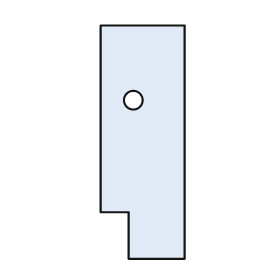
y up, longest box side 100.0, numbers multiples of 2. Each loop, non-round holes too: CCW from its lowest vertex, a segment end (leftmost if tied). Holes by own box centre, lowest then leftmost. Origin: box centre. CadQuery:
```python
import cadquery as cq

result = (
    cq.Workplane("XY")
    .moveTo(-6.0, -50.0)
    .lineTo(18.0, -50.0)
    .lineTo(18.0, 50.0)
    .lineTo(-18.0, 50.0)
    .lineTo(-18.0, -30.0)
    .lineTo(-6.0, -30.0)
    .close()
    .moveTo(-4.0, 18.0)
    .circle(4.0)
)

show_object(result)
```